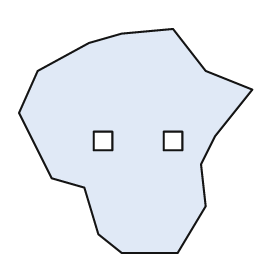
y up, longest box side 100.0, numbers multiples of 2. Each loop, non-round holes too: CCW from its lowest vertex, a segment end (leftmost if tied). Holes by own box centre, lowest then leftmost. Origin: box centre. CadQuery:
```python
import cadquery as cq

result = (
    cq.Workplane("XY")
    .moveTo(-6.0, -48.0)
    .lineTo(18.0, -48.0)
    .lineTo(30.0, -28.0)
    .lineTo(28.0, -10.0)
    .lineTo(34.0, 2.0)
    .lineTo(50.0, 22.0)
    .lineTo(30.0, 30.0)
    .lineTo(16.0, 48.0)
    .lineTo(-6.0, 46.0)
    .lineTo(-20.0, 42.0)
    .lineTo(-42.0, 30.0)
    .lineTo(-50.0, 12.0)
    .lineTo(-36.0, -16.0)
    .lineTo(-22.0, -20.0)
    .lineTo(-16.0, -40.0)
    .close()
    .moveTo(-18.0, -4.0)
    .lineTo(-10.0, -4.0)
    .lineTo(-10.0, 4.0)
    .lineTo(-18.0, 4.0)
    .close()
    .moveTo(12.0, -4.0)
    .lineTo(20.0, -4.0)
    .lineTo(20.0, 4.0)
    .lineTo(12.0, 4.0)
    .close()
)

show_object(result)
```